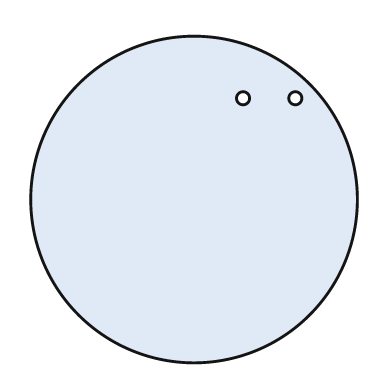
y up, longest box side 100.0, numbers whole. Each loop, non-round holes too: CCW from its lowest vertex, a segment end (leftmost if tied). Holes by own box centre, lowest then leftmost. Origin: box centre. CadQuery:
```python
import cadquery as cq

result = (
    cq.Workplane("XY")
    .moveTo(0.0, 0.0)
    .circle(50.0)
    .moveTo(15.0, 31.0)
    .circle(2.0)
    .moveTo(31.0, 31.0)
    .circle(2.0)
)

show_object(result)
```